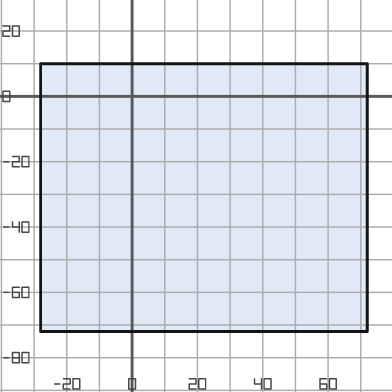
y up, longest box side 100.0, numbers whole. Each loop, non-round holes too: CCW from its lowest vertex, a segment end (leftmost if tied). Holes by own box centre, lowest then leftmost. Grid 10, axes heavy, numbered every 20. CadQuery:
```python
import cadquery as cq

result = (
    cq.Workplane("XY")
    .moveTo(-28.0, -72.0)
    .lineTo(72.0, -72.0)
    .lineTo(72.0, 10.0)
    .lineTo(-28.0, 10.0)
    .close()
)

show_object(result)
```